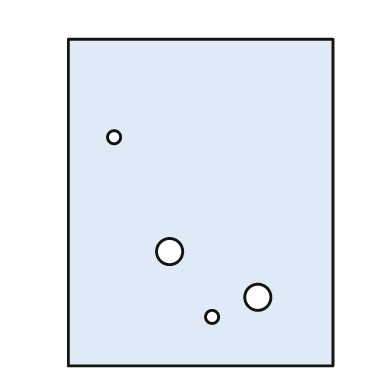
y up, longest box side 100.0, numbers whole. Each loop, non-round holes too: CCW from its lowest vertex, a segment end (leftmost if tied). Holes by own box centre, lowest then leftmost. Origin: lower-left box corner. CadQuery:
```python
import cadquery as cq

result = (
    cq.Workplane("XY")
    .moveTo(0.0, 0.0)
    .lineTo(81.0, 0.0)
    .lineTo(81.0, 100.0)
    .lineTo(0.0, 100.0)
    .close()
    .moveTo(44.0, 15.0)
    .circle(2.0)
    .moveTo(58.0, 21.0)
    .circle(4.0)
    .moveTo(31.0, 35.0)
    .circle(4.0)
    .moveTo(14.0, 70.0)
    .circle(2.0)
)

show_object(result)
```